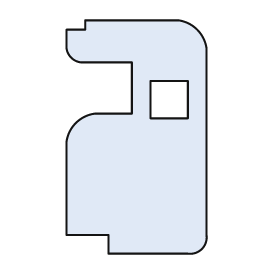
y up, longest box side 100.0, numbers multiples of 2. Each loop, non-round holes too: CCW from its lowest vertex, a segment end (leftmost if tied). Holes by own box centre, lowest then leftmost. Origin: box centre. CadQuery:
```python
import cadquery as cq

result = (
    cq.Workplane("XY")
    .moveTo(-12.0, -50.0)
    .lineTo(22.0, -50.0)
    .threePointArc((28.0, -48.0), (30.0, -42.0))
    .lineTo(30.0, 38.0)
    .threePointArc((26.0, 46.0), (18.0, 50.0))
    .lineTo(-22.0, 50.0)
    .lineTo(-22.0, 46.0)
    .lineTo(-30.0, 46.0)
    .lineTo(-30.0, 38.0)
    .threePointArc((-28.0, 34.0), (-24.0, 32.0))
    .lineTo(-2.0, 32.0)
    .lineTo(-2.0, 10.0)
    .lineTo(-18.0, 10.0)
    .threePointArc((-26.0, 6.0), (-30.0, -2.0))
    .lineTo(-30.0, -42.0)
    .lineTo(-12.0, -42.0)
    .close()
    .moveTo(6.0, 8.0)
    .lineTo(22.0, 8.0)
    .lineTo(22.0, 24.0)
    .lineTo(6.0, 24.0)
    .close()
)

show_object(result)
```